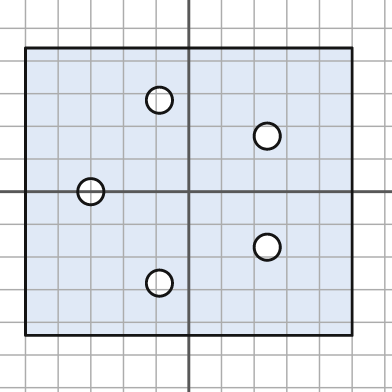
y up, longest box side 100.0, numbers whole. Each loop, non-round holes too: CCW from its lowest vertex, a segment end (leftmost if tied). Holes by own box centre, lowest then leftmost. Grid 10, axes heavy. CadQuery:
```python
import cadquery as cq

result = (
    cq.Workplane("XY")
    .moveTo(-50.0, -44.0)
    .lineTo(50.0, -44.0)
    .lineTo(50.0, 44.0)
    .lineTo(-50.0, 44.0)
    .close()
    .moveTo(-9.0, -28.0)
    .circle(4.0)
    .moveTo(24.0, -17.0)
    .circle(4.0)
    .moveTo(-30.0, 0.0)
    .circle(4.0)
    .moveTo(24.0, 17.0)
    .circle(4.0)
    .moveTo(-9.0, 28.0)
    .circle(4.0)
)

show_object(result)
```